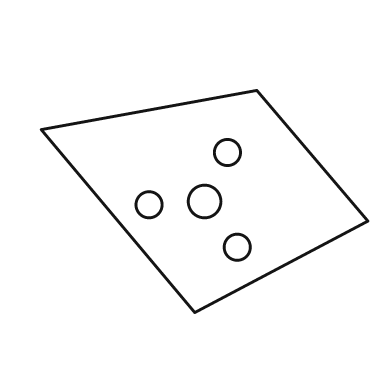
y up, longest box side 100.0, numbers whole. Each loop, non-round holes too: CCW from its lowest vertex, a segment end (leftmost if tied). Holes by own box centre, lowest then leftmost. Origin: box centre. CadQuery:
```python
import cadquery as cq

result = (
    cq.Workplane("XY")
    .moveTo(-3.0, -34.0)
    .lineTo(50.0, -6.0)
    .lineTo(16.0, 34.0)
    .lineTo(-50.0, 22.0)
    .close()
    .moveTo(10.0, -14.0)
    .circle(4.0)
    .moveTo(-17.0, -1.0)
    .circle(4.0)
    .moveTo(0.0, 0.0)
    .circle(5.0)
    .moveTo(7.0, 15.0)
    .circle(4.0)
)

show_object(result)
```